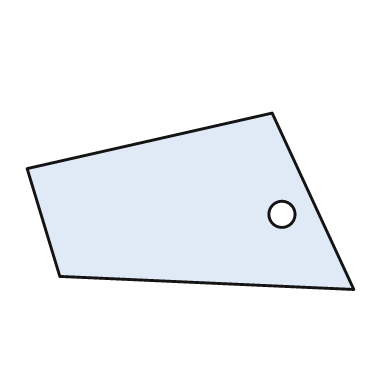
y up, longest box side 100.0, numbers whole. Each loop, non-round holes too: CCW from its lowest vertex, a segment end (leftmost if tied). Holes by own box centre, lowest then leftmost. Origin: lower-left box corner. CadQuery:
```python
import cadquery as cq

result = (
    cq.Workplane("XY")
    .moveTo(100.0, 0.0)
    .lineTo(75.0, 54.0)
    .lineTo(0.0, 37.0)
    .lineTo(10.0, 4.0)
    .close()
    .moveTo(78.0, 23.0)
    .circle(4.0)
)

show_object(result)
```